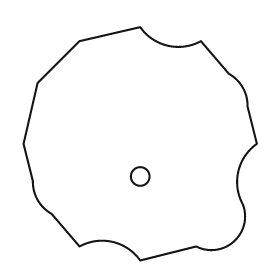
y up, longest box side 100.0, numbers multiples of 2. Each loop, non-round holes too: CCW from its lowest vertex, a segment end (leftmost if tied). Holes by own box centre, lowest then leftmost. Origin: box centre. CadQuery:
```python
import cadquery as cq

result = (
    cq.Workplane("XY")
    .moveTo(0.0, -50.0)
    .lineTo(24.0, -44.0)
    .threePointArc((40.0, -42.0), (44.0, -26.0))
    .threePointArc((42.0, -12.0), (50.0, 0.0))
    .lineTo(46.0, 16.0)
    .threePointArc((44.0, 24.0), (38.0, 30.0))
    .lineTo(26.0, 44.0)
    .threePointArc((12.0, 42.0), (0.0, 50.0))
    .lineTo(-26.0, 44.0)
    .lineTo(-44.0, 26.0)
    .lineTo(-50.0, 0.0)
    .lineTo(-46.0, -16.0)
    .threePointArc((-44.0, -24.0), (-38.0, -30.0))
    .lineTo(-26.0, -44.0)
    .threePointArc((-12.0, -42.0), (0.0, -50.0))
    .close()
    .moveTo(0.0, -14.0)
    .circle(4.0)
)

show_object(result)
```